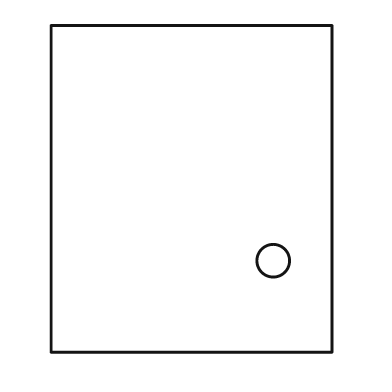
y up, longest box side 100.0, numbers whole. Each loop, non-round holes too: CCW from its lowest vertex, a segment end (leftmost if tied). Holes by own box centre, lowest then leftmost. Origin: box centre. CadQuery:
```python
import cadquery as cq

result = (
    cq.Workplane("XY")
    .moveTo(-43.0, -50.0)
    .lineTo(43.0, -50.0)
    .lineTo(43.0, 50.0)
    .lineTo(-43.0, 50.0)
    .close()
    .moveTo(25.0, -22.0)
    .circle(5.0)
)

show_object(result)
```